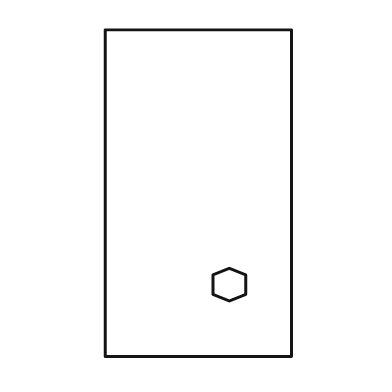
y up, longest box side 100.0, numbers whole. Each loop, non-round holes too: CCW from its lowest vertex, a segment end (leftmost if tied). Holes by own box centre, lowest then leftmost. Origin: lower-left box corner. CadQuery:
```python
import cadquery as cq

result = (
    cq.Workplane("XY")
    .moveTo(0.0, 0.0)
    .lineTo(57.0, 0.0)
    .lineTo(57.0, 100.0)
    .lineTo(0.0, 100.0)
    .close()
    .moveTo(38.0, 17.0)
    .lineTo(43.0, 19.0)
    .lineTo(43.0, 25.0)
    .lineTo(38.0, 27.0)
    .lineTo(33.0, 25.0)
    .lineTo(33.0, 19.0)
    .close()
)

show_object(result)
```